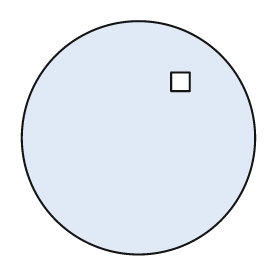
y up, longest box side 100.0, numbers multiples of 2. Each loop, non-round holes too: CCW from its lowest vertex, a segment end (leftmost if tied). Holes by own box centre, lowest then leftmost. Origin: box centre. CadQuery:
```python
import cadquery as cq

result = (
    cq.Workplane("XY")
    .moveTo(0.0, 0.0)
    .circle(50.0)
    .moveTo(14.0, 20.0)
    .lineTo(22.0, 20.0)
    .lineTo(22.0, 28.0)
    .lineTo(14.0, 28.0)
    .close()
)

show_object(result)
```